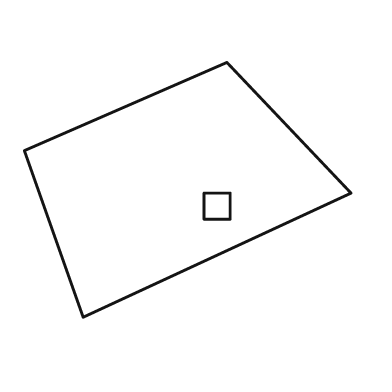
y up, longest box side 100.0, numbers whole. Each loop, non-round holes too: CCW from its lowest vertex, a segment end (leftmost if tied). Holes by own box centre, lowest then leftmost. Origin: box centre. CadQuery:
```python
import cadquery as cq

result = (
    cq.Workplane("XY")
    .moveTo(-32.0, -39.0)
    .lineTo(50.0, -1.0)
    .lineTo(12.0, 39.0)
    .lineTo(-50.0, 12.0)
    .close()
    .moveTo(5.0, -9.0)
    .lineTo(13.0, -9.0)
    .lineTo(13.0, -1.0)
    .lineTo(5.0, -1.0)
    .close()
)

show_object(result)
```